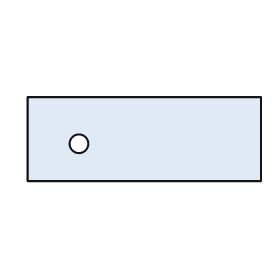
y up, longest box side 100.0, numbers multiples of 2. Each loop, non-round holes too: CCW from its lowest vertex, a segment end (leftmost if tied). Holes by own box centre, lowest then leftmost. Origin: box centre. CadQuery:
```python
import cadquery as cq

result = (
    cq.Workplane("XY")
    .moveTo(-50.0, -18.0)
    .lineTo(50.0, -18.0)
    .lineTo(50.0, 18.0)
    .lineTo(-50.0, 18.0)
    .close()
    .moveTo(-28.0, -2.0)
    .circle(4.0)
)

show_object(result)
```